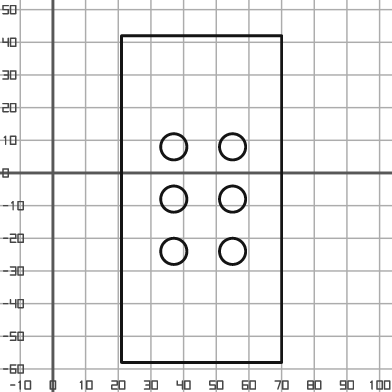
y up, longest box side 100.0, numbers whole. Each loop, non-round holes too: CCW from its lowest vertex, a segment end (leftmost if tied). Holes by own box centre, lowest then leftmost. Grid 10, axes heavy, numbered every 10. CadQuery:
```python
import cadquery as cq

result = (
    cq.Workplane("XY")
    .moveTo(21.0, -58.0)
    .lineTo(70.0, -58.0)
    .lineTo(70.0, 42.0)
    .lineTo(21.0, 42.0)
    .close()
    .moveTo(37.0, -24.0)
    .circle(4.0)
    .moveTo(55.0, -24.0)
    .circle(4.0)
    .moveTo(37.0, -8.0)
    .circle(4.0)
    .moveTo(55.0, -8.0)
    .circle(4.0)
    .moveTo(37.0, 8.0)
    .circle(4.0)
    .moveTo(55.0, 8.0)
    .circle(4.0)
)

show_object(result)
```